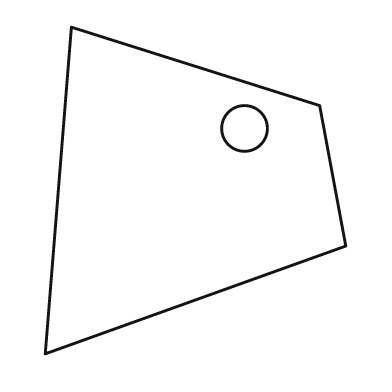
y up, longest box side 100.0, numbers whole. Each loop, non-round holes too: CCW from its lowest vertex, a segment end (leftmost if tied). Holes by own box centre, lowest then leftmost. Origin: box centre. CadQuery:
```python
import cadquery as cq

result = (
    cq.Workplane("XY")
    .moveTo(-46.0, -50.0)
    .lineTo(46.0, -17.0)
    .lineTo(38.0, 26.0)
    .lineTo(-38.0, 50.0)
    .close()
    .moveTo(15.0, 19.0)
    .circle(7.0)
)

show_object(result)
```